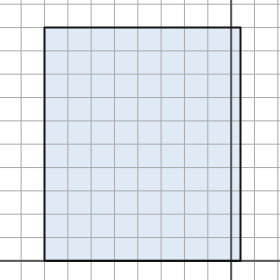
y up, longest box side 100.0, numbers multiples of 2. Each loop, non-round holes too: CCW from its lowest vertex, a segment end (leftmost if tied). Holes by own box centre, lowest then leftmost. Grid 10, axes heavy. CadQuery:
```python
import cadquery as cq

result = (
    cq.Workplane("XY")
    .moveTo(-80.0, 0.0)
    .lineTo(4.0, 0.0)
    .lineTo(4.0, 100.0)
    .lineTo(-80.0, 100.0)
    .close()
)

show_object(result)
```